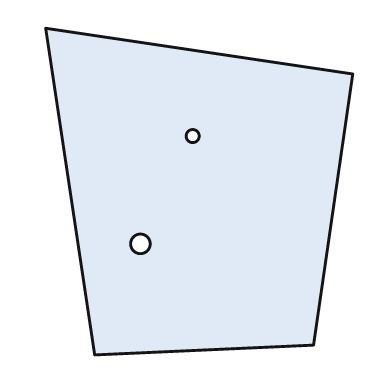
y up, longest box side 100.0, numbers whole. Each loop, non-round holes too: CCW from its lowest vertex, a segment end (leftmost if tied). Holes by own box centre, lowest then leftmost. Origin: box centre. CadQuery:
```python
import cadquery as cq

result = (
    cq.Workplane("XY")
    .moveTo(-32.0, -50.0)
    .lineTo(35.0, -47.0)
    .lineTo(47.0, 36.0)
    .lineTo(-47.0, 50.0)
    .close()
    .moveTo(-18.0, -16.0)
    .circle(3.0)
    .moveTo(-2.0, 17.0)
    .circle(2.0)
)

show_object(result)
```